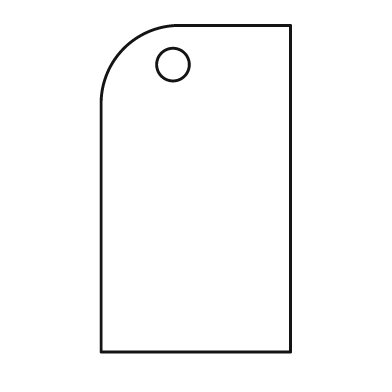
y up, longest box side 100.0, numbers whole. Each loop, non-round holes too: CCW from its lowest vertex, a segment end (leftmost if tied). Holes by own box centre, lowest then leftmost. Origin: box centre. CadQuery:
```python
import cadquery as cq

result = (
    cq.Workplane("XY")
    .moveTo(-29.0, -50.0)
    .lineTo(29.0, -50.0)
    .lineTo(29.0, 50.0)
    .lineTo(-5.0, 50.0)
    .threePointArc((-22.0, 43.0), (-29.0, 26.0))
    .close()
    .moveTo(-7.0, 38.0)
    .circle(5.0)
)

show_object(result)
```